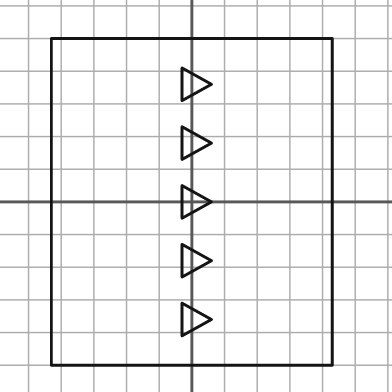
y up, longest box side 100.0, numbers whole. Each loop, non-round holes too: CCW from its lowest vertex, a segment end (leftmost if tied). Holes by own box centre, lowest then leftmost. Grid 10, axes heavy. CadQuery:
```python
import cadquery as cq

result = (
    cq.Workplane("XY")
    .moveTo(-43.0, -50.0)
    .lineTo(43.0, -50.0)
    .lineTo(43.0, 50.0)
    .lineTo(-43.0, 50.0)
    .close()
    .moveTo(-3.0, -41.0)
    .lineTo(6.0, -36.0)
    .lineTo(-3.0, -31.0)
    .close()
    .moveTo(-3.0, -23.0)
    .lineTo(6.0, -18.0)
    .lineTo(-3.0, -13.0)
    .close()
    .moveTo(-3.0, -5.0)
    .lineTo(6.0, 0.0)
    .lineTo(-3.0, 5.0)
    .close()
    .moveTo(-3.0, 13.0)
    .lineTo(6.0, 18.0)
    .lineTo(-3.0, 23.0)
    .close()
    .moveTo(-3.0, 31.0)
    .lineTo(6.0, 36.0)
    .lineTo(-3.0, 41.0)
    .close()
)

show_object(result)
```